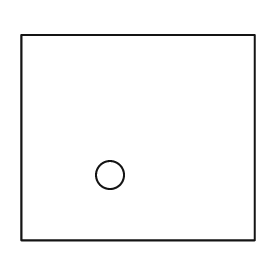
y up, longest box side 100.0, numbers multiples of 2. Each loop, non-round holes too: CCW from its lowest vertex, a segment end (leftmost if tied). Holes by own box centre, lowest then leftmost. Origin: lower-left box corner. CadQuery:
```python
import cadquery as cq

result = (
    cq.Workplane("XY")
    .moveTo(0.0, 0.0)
    .lineTo(100.0, 0.0)
    .lineTo(100.0, 88.0)
    .lineTo(0.0, 88.0)
    .close()
    .moveTo(38.0, 28.0)
    .circle(6.0)
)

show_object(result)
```